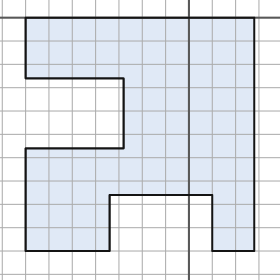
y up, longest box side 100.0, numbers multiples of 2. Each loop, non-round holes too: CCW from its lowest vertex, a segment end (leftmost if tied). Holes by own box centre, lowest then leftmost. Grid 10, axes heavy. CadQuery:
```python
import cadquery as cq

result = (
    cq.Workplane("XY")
    .moveTo(-70.0, -100.0)
    .lineTo(-34.0, -100.0)
    .lineTo(-34.0, -76.0)
    .lineTo(10.0, -76.0)
    .lineTo(10.0, -100.0)
    .lineTo(28.0, -100.0)
    .lineTo(28.0, 0.0)
    .lineTo(-70.0, 0.0)
    .lineTo(-70.0, -26.0)
    .lineTo(-28.0, -26.0)
    .lineTo(-28.0, -56.0)
    .lineTo(-70.0, -56.0)
    .close()
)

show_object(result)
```